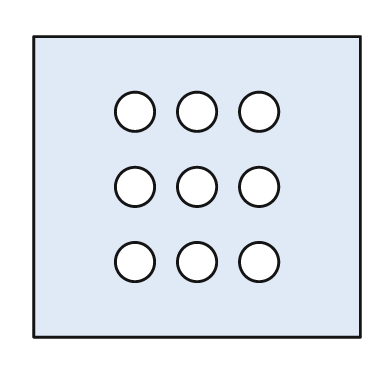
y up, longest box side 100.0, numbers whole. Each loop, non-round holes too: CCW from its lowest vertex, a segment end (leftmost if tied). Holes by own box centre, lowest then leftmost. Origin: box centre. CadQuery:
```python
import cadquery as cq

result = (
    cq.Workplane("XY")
    .moveTo(-50.0, -46.0)
    .lineTo(50.0, -46.0)
    .lineTo(50.0, 46.0)
    .lineTo(-50.0, 46.0)
    .close()
    .moveTo(-19.0, -23.0)
    .circle(6.0)
    .moveTo(0.0, -23.0)
    .circle(6.0)
    .moveTo(19.0, -23.0)
    .circle(6.0)
    .moveTo(-19.0, 0.0)
    .circle(6.0)
    .moveTo(0.0, 0.0)
    .circle(6.0)
    .moveTo(19.0, 0.0)
    .circle(6.0)
    .moveTo(-19.0, 23.0)
    .circle(6.0)
    .moveTo(0.0, 23.0)
    .circle(6.0)
    .moveTo(19.0, 23.0)
    .circle(6.0)
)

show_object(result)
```